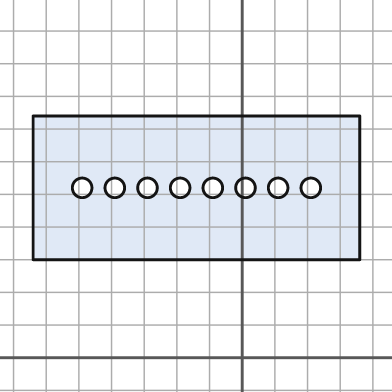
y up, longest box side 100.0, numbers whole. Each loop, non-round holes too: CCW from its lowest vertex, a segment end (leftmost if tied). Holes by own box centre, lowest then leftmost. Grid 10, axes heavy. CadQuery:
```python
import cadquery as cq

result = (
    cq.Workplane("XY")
    .moveTo(-64.0, 30.0)
    .lineTo(36.0, 30.0)
    .lineTo(36.0, 74.0)
    .lineTo(-64.0, 74.0)
    .close()
    .moveTo(-49.0, 52.0)
    .circle(3.0)
    .moveTo(-39.0, 52.0)
    .circle(3.0)
    .moveTo(-29.0, 52.0)
    .circle(3.0)
    .moveTo(-19.0, 52.0)
    .circle(3.0)
    .moveTo(-9.0, 52.0)
    .circle(3.0)
    .moveTo(1.0, 52.0)
    .circle(3.0)
    .moveTo(11.0, 52.0)
    .circle(3.0)
    .moveTo(21.0, 52.0)
    .circle(3.0)
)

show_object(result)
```